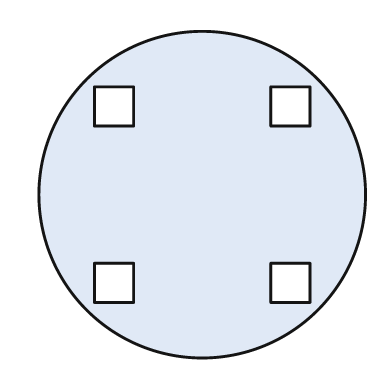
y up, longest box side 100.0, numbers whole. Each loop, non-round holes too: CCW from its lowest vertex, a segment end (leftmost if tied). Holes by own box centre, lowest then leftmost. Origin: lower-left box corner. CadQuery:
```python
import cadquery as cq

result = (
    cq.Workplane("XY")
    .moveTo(50.0, 50.0)
    .circle(50.0)
    .moveTo(17.0, 17.0)
    .lineTo(29.0, 17.0)
    .lineTo(29.0, 29.0)
    .lineTo(17.0, 29.0)
    .close()
    .moveTo(71.0, 17.0)
    .lineTo(83.0, 17.0)
    .lineTo(83.0, 29.0)
    .lineTo(71.0, 29.0)
    .close()
    .moveTo(17.0, 71.0)
    .lineTo(29.0, 71.0)
    .lineTo(29.0, 83.0)
    .lineTo(17.0, 83.0)
    .close()
    .moveTo(71.0, 71.0)
    .lineTo(83.0, 71.0)
    .lineTo(83.0, 83.0)
    .lineTo(71.0, 83.0)
    .close()
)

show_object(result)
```